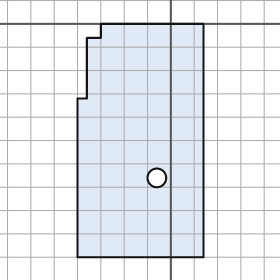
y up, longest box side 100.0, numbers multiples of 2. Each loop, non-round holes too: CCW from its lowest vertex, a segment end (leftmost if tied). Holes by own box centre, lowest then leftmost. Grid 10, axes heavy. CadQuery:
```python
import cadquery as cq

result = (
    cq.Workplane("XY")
    .moveTo(-40.0, -100.0)
    .lineTo(14.0, -100.0)
    .lineTo(14.0, 0.0)
    .lineTo(-30.0, 0.0)
    .lineTo(-30.0, -6.0)
    .lineTo(-36.0, -6.0)
    .lineTo(-36.0, -32.0)
    .lineTo(-40.0, -32.0)
    .close()
    .moveTo(-6.0, -66.0)
    .circle(4.0)
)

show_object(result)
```